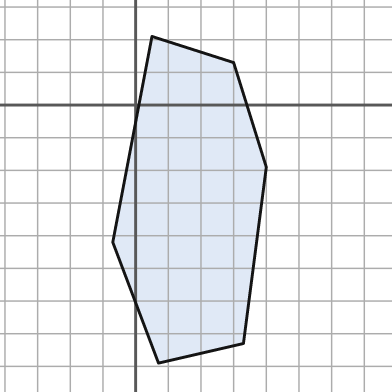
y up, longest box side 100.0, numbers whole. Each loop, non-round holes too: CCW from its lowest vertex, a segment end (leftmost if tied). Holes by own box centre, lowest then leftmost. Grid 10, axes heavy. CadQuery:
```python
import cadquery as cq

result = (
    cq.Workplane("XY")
    .moveTo(7.0, -79.0)
    .lineTo(33.0, -73.0)
    .lineTo(40.0, -19.0)
    .lineTo(30.0, 13.0)
    .lineTo(5.0, 21.0)
    .lineTo(-7.0, -42.0)
    .close()
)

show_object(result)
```